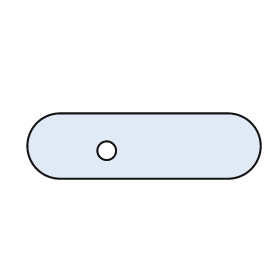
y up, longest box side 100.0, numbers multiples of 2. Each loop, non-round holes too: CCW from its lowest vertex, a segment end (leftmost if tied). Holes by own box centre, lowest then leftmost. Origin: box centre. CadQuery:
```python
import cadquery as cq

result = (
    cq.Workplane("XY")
    .moveTo(-36.0, -14.0)
    .lineTo(36.0, -14.0)
    .threePointArc((50.0, 0.0), (36.0, 14.0))
    .lineTo(-36.0, 14.0)
    .threePointArc((-50.0, 0.0), (-36.0, -14.0))
    .close()
    .moveTo(-16.0, -2.0)
    .circle(4.0)
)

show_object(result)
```